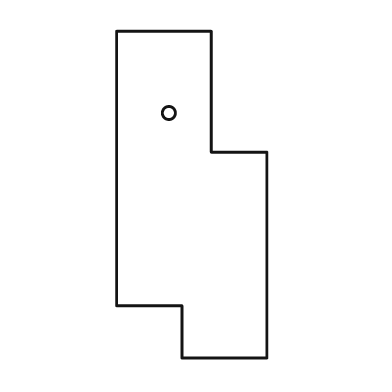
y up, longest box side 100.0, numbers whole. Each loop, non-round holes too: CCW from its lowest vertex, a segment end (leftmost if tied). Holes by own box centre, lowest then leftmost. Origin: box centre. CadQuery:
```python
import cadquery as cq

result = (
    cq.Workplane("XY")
    .moveTo(-3.0, -50.0)
    .lineTo(23.0, -50.0)
    .lineTo(23.0, 13.0)
    .lineTo(6.0, 13.0)
    .lineTo(6.0, 50.0)
    .lineTo(-23.0, 50.0)
    .lineTo(-23.0, -34.0)
    .lineTo(-3.0, -34.0)
    .close()
    .moveTo(-7.0, 25.0)
    .circle(2.0)
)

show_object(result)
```